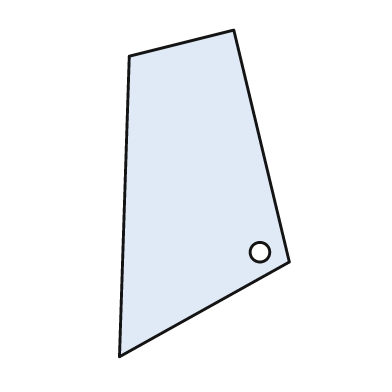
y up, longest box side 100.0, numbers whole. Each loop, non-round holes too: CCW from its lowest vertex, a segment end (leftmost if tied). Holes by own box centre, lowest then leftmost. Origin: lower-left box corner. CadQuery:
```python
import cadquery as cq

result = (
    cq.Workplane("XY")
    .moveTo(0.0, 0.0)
    .lineTo(52.0, 29.0)
    .lineTo(35.0, 100.0)
    .lineTo(3.0, 92.0)
    .close()
    .moveTo(43.0, 32.0)
    .circle(3.0)
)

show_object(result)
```